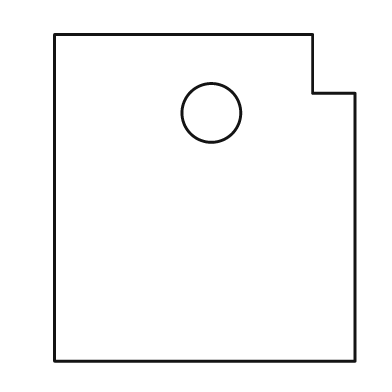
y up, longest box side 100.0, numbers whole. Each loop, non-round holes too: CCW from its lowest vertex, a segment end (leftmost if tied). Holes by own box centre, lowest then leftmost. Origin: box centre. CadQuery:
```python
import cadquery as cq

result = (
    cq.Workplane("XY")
    .moveTo(-46.0, -50.0)
    .lineTo(46.0, -50.0)
    .lineTo(46.0, 32.0)
    .lineTo(33.0, 32.0)
    .lineTo(33.0, 50.0)
    .lineTo(-46.0, 50.0)
    .close()
    .moveTo(2.0, 26.0)
    .circle(9.0)
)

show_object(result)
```